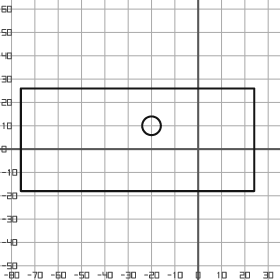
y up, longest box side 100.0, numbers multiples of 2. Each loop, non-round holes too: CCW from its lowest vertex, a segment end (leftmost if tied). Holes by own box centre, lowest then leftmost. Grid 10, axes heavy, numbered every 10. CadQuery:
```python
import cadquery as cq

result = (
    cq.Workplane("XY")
    .moveTo(-76.0, -18.0)
    .lineTo(24.0, -18.0)
    .lineTo(24.0, 26.0)
    .lineTo(-76.0, 26.0)
    .close()
    .moveTo(-20.0, 10.0)
    .circle(4.0)
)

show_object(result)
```